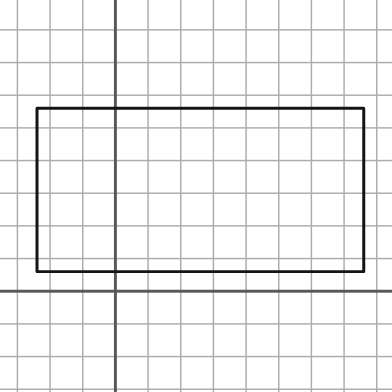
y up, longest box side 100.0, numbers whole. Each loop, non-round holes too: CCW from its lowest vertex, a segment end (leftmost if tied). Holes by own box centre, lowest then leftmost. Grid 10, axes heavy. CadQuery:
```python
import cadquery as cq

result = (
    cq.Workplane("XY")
    .moveTo(-24.0, 6.0)
    .lineTo(76.0, 6.0)
    .lineTo(76.0, 56.0)
    .lineTo(-24.0, 56.0)
    .close()
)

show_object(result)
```